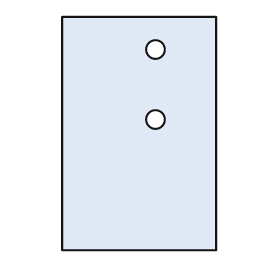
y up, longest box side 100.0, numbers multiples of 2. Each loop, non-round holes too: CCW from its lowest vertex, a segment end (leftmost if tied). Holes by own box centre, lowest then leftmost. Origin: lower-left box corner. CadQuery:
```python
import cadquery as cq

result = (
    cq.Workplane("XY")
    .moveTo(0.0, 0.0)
    .lineTo(66.0, 0.0)
    .lineTo(66.0, 100.0)
    .lineTo(0.0, 100.0)
    .close()
    .moveTo(40.0, 56.0)
    .circle(4.0)
    .moveTo(40.0, 86.0)
    .circle(4.0)
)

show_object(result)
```